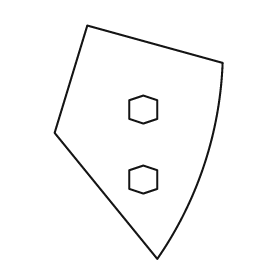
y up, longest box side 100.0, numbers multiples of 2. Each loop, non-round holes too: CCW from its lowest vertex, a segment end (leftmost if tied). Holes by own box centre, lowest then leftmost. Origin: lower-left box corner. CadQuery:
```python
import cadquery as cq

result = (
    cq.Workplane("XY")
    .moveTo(44.0, 0.0)
    .threePointArc((64.0, 40.0), (72.0, 84.0))
    .lineTo(14.0, 100.0)
    .lineTo(0.0, 54.0)
    .close()
    .moveTo(38.0, 28.0)
    .lineTo(44.0, 30.0)
    .lineTo(44.0, 38.0)
    .lineTo(38.0, 40.0)
    .lineTo(32.0, 38.0)
    .lineTo(32.0, 30.0)
    .close()
    .moveTo(38.0, 58.0)
    .lineTo(44.0, 60.0)
    .lineTo(44.0, 68.0)
    .lineTo(38.0, 70.0)
    .lineTo(32.0, 68.0)
    .lineTo(32.0, 60.0)
    .close()
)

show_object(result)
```